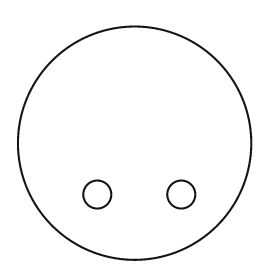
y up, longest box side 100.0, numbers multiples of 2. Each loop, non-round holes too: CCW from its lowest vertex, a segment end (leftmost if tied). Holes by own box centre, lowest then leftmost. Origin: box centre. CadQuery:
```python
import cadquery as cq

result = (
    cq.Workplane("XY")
    .moveTo(0.0, 0.0)
    .circle(50.0)
    .moveTo(-16.0, -22.0)
    .circle(6.0)
    .moveTo(20.0, -22.0)
    .circle(6.0)
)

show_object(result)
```